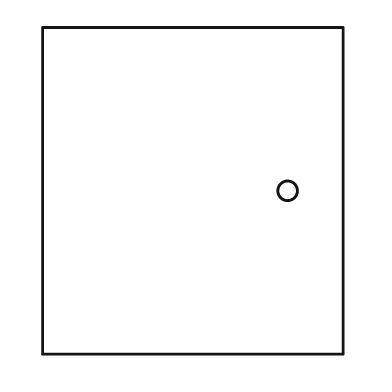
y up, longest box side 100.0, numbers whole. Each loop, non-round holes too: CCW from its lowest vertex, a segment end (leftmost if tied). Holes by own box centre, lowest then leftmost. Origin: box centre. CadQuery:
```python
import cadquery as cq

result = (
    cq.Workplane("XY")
    .moveTo(-46.0, -50.0)
    .lineTo(46.0, -50.0)
    .lineTo(46.0, 50.0)
    .lineTo(-46.0, 50.0)
    .close()
    .moveTo(29.0, 0.0)
    .circle(3.0)
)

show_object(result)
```